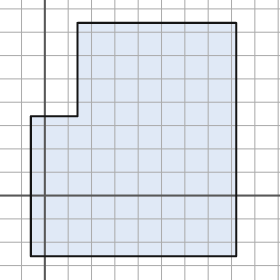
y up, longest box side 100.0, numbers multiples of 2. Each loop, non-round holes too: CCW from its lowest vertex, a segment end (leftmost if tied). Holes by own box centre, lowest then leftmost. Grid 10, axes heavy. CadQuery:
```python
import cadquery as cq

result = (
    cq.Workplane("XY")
    .moveTo(-6.0, -26.0)
    .lineTo(82.0, -26.0)
    .lineTo(82.0, 74.0)
    .lineTo(14.0, 74.0)
    .lineTo(14.0, 34.0)
    .lineTo(-6.0, 34.0)
    .close()
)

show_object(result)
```